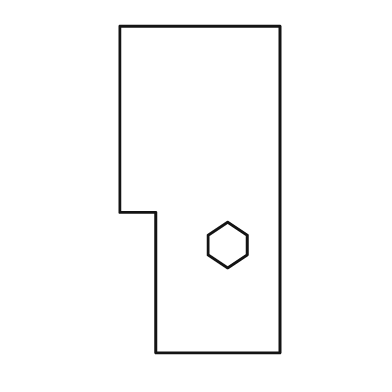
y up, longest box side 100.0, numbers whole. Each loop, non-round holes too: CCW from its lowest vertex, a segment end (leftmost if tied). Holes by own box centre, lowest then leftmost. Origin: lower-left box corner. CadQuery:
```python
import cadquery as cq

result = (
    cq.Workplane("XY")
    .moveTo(11.0, 0.0)
    .lineTo(49.0, 0.0)
    .lineTo(49.0, 100.0)
    .lineTo(0.0, 100.0)
    .lineTo(0.0, 43.0)
    .lineTo(11.0, 43.0)
    .close()
    .moveTo(33.0, 26.0)
    .lineTo(39.0, 30.0)
    .lineTo(39.0, 36.0)
    .lineTo(33.0, 40.0)
    .lineTo(27.0, 36.0)
    .lineTo(27.0, 30.0)
    .close()
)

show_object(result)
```